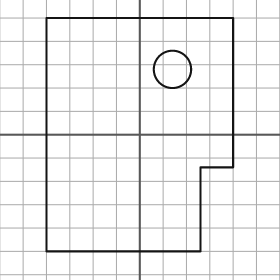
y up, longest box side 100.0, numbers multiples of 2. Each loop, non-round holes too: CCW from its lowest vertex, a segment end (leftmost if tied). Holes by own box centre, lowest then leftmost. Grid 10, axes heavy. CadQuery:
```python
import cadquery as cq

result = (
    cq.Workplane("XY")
    .moveTo(-40.0, -50.0)
    .lineTo(26.0, -50.0)
    .lineTo(26.0, -14.0)
    .lineTo(40.0, -14.0)
    .lineTo(40.0, 50.0)
    .lineTo(-40.0, 50.0)
    .close()
    .moveTo(14.0, 28.0)
    .circle(8.0)
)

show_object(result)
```